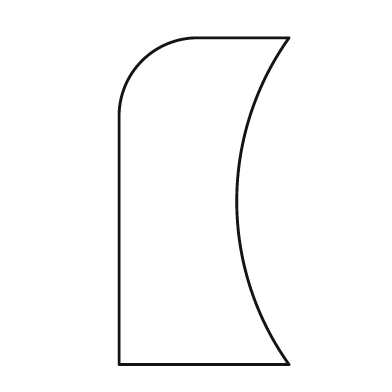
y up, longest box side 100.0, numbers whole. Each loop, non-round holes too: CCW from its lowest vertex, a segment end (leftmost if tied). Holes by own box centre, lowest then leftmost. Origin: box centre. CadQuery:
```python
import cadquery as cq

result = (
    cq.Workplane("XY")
    .moveTo(-26.0, -50.0)
    .lineTo(26.0, -50.0)
    .threePointArc((10.0, 0.0), (26.0, 50.0))
    .lineTo(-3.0, 50.0)
    .threePointArc((-19.0, 43.0), (-26.0, 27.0))
    .close()
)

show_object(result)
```